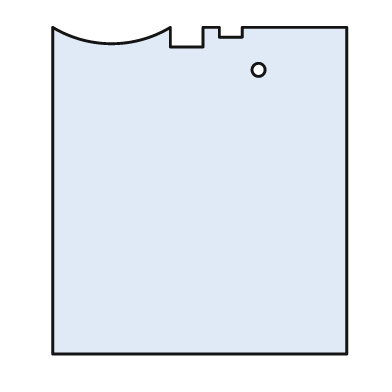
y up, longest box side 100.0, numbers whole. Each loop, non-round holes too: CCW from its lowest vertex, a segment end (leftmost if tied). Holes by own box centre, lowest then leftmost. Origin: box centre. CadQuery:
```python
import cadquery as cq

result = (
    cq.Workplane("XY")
    .moveTo(-45.0, -50.0)
    .lineTo(45.0, -50.0)
    .lineTo(45.0, 50.0)
    .lineTo(13.0, 50.0)
    .lineTo(13.0, 47.0)
    .lineTo(6.0, 47.0)
    .lineTo(6.0, 50.0)
    .lineTo(1.0, 50.0)
    .lineTo(1.0, 44.0)
    .lineTo(-9.0, 44.0)
    .lineTo(-9.0, 50.0)
    .threePointArc((-27.0, 45.0), (-45.0, 50.0))
    .close()
    .moveTo(18.0, 37.0)
    .circle(2.0)
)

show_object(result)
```